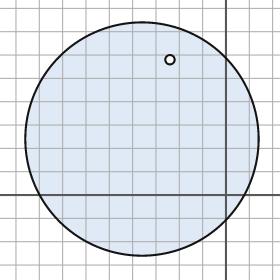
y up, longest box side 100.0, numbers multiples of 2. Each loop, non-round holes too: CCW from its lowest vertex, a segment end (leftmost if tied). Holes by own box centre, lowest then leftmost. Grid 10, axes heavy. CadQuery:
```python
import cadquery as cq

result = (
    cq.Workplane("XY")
    .moveTo(-36.0, 24.0)
    .circle(50.0)
    .moveTo(-24.0, 58.0)
    .circle(2.0)
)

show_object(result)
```